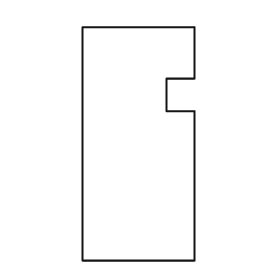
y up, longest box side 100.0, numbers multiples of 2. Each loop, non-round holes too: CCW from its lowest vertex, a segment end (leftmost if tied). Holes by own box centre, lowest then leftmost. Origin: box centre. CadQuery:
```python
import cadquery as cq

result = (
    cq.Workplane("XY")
    .moveTo(-24.0, -50.0)
    .lineTo(24.0, -50.0)
    .lineTo(24.0, 14.0)
    .lineTo(12.0, 14.0)
    .lineTo(12.0, 28.0)
    .lineTo(24.0, 28.0)
    .lineTo(24.0, 50.0)
    .lineTo(-24.0, 50.0)
    .close()
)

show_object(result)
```